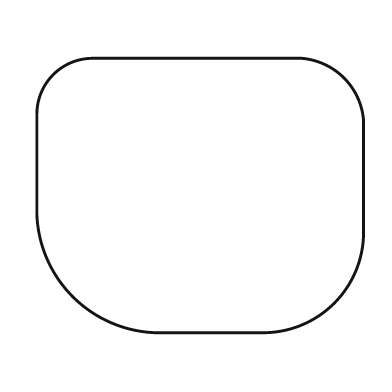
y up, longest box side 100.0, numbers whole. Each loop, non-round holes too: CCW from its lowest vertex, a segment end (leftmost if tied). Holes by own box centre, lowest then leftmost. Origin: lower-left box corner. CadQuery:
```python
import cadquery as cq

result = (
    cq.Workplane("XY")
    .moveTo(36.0, 0.0)
    .lineTo(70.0, 0.0)
    .threePointArc((91.0, 9.0), (100.0, 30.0))
    .lineTo(100.0, 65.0)
    .threePointArc((94.0, 78.0), (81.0, 84.0))
    .lineTo(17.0, 84.0)
    .threePointArc((5.0, 79.0), (0.0, 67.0))
    .lineTo(0.0, 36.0)
    .threePointArc((11.0, 11.0), (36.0, 0.0))
    .close()
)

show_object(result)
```